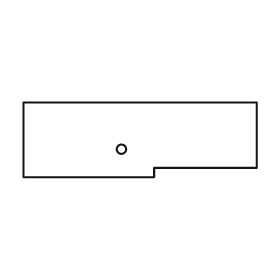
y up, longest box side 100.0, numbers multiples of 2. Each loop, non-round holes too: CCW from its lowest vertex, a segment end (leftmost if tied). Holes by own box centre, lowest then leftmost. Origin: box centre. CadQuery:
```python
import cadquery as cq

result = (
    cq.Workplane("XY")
    .moveTo(-50.0, -16.0)
    .lineTo(6.0, -16.0)
    .lineTo(6.0, -12.0)
    .lineTo(50.0, -12.0)
    .lineTo(50.0, 16.0)
    .lineTo(-50.0, 16.0)
    .close()
    .moveTo(-8.0, -4.0)
    .circle(2.0)
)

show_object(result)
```